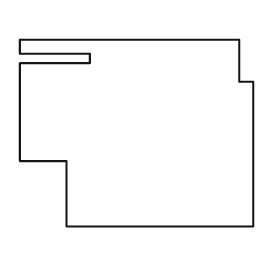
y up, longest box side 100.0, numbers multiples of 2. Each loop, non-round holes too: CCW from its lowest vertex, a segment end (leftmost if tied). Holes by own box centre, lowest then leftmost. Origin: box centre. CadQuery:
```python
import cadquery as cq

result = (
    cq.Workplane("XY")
    .moveTo(-30.0, -40.0)
    .lineTo(50.0, -40.0)
    .lineTo(50.0, 22.0)
    .lineTo(44.0, 22.0)
    .lineTo(44.0, 40.0)
    .lineTo(-50.0, 40.0)
    .lineTo(-50.0, 34.0)
    .lineTo(-20.0, 34.0)
    .lineTo(-20.0, 30.0)
    .lineTo(-50.0, 30.0)
    .lineTo(-50.0, -12.0)
    .lineTo(-30.0, -12.0)
    .close()
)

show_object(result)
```